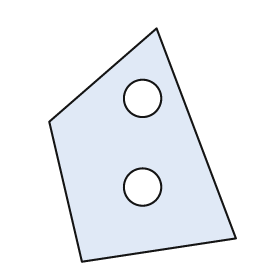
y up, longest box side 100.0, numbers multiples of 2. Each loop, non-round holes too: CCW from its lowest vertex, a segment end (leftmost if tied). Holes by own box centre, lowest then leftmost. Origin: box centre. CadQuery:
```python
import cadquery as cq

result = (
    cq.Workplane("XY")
    .moveTo(-26.0, -50.0)
    .lineTo(40.0, -40.0)
    .lineTo(6.0, 50.0)
    .lineTo(-40.0, 10.0)
    .close()
    .moveTo(0.0, -18.0)
    .circle(8.0)
    .moveTo(0.0, 20.0)
    .circle(8.0)
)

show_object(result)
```